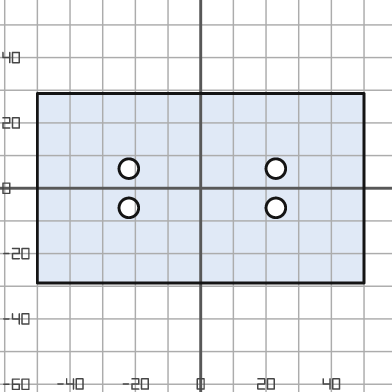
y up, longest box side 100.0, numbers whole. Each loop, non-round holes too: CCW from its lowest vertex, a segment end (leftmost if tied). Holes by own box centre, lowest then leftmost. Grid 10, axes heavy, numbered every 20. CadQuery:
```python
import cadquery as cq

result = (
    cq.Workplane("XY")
    .moveTo(-50.0, -29.0)
    .lineTo(50.0, -29.0)
    .lineTo(50.0, 29.0)
    .lineTo(-50.0, 29.0)
    .close()
    .moveTo(-22.0, -6.0)
    .circle(3.0)
    .moveTo(23.0, -6.0)
    .circle(3.0)
    .moveTo(-22.0, 6.0)
    .circle(3.0)
    .moveTo(23.0, 6.0)
    .circle(3.0)
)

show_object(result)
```